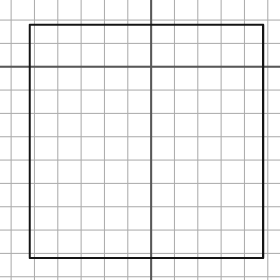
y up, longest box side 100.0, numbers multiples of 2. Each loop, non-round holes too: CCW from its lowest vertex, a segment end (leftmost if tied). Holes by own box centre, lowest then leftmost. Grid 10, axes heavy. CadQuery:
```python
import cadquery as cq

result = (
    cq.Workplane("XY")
    .moveTo(-52.0, -82.0)
    .lineTo(48.0, -82.0)
    .lineTo(48.0, 18.0)
    .lineTo(-52.0, 18.0)
    .close()
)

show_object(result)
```